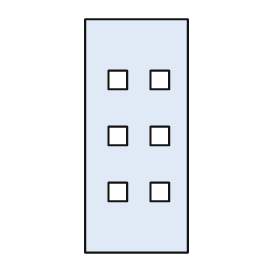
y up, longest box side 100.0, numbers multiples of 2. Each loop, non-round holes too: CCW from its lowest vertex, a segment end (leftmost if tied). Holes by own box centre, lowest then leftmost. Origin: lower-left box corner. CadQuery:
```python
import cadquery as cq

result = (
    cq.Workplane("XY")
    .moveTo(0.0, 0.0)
    .lineTo(44.0, 0.0)
    .lineTo(44.0, 100.0)
    .lineTo(0.0, 100.0)
    .close()
    .moveTo(10.0, 22.0)
    .lineTo(18.0, 22.0)
    .lineTo(18.0, 30.0)
    .lineTo(10.0, 30.0)
    .close()
    .moveTo(28.0, 22.0)
    .lineTo(36.0, 22.0)
    .lineTo(36.0, 30.0)
    .lineTo(28.0, 30.0)
    .close()
    .moveTo(10.0, 46.0)
    .lineTo(18.0, 46.0)
    .lineTo(18.0, 54.0)
    .lineTo(10.0, 54.0)
    .close()
    .moveTo(28.0, 46.0)
    .lineTo(36.0, 46.0)
    .lineTo(36.0, 54.0)
    .lineTo(28.0, 54.0)
    .close()
    .moveTo(10.0, 70.0)
    .lineTo(18.0, 70.0)
    .lineTo(18.0, 78.0)
    .lineTo(10.0, 78.0)
    .close()
    .moveTo(28.0, 70.0)
    .lineTo(36.0, 70.0)
    .lineTo(36.0, 78.0)
    .lineTo(28.0, 78.0)
    .close()
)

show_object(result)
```